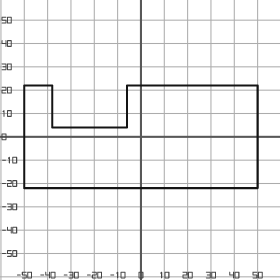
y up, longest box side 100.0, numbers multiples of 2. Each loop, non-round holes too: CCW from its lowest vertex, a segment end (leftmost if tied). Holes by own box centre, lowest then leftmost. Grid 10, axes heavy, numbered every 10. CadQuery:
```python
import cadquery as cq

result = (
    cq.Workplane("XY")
    .moveTo(-50.0, -22.0)
    .lineTo(50.0, -22.0)
    .lineTo(50.0, 22.0)
    .lineTo(-6.0, 22.0)
    .lineTo(-6.0, 4.0)
    .lineTo(-38.0, 4.0)
    .lineTo(-38.0, 22.0)
    .lineTo(-50.0, 22.0)
    .close()
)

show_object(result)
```